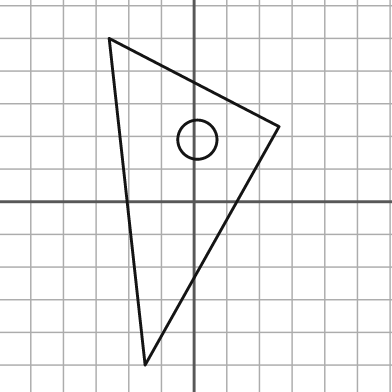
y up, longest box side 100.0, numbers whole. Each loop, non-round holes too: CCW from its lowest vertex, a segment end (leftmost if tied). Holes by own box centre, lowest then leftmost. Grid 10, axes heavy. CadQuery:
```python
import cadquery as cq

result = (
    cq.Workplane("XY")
    .moveTo(-15.0, -50.0)
    .lineTo(26.0, 23.0)
    .lineTo(-26.0, 50.0)
    .close()
    .moveTo(1.0, 19.0)
    .circle(6.0)
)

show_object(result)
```